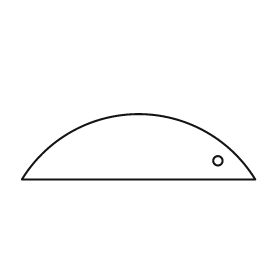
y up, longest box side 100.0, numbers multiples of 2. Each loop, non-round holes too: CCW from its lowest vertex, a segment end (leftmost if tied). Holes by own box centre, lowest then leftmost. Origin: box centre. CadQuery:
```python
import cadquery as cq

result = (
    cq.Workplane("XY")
    .moveTo(-50.0, -14.0)
    .lineTo(50.0, -14.0)
    .threePointArc((0.0, 14.0), (-50.0, -14.0))
    .close()
    .moveTo(34.0, -6.0)
    .circle(2.0)
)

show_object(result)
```